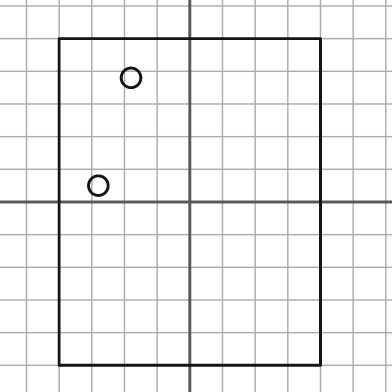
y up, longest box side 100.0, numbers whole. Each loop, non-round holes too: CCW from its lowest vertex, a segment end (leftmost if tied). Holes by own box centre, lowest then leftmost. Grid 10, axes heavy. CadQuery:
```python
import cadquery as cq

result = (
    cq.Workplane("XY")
    .moveTo(-40.0, -50.0)
    .lineTo(40.0, -50.0)
    .lineTo(40.0, 50.0)
    .lineTo(-40.0, 50.0)
    .close()
    .moveTo(-28.0, 5.0)
    .circle(3.0)
    .moveTo(-18.0, 38.0)
    .circle(3.0)
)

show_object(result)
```